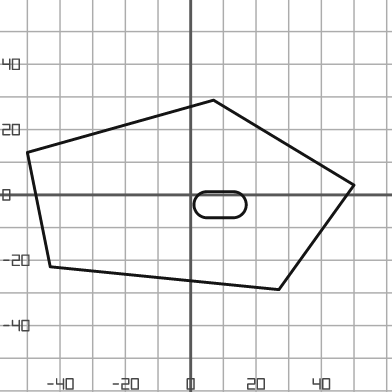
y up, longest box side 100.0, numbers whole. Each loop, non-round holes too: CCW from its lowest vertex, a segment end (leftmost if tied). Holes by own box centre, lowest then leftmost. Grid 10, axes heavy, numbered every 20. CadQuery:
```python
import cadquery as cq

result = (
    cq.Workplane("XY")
    .moveTo(27.0, -29.0)
    .lineTo(50.0, 3.0)
    .lineTo(7.0, 29.0)
    .lineTo(-50.0, 13.0)
    .lineTo(-43.0, -22.0)
    .close()
    .moveTo(5.0, -7.0)
    .lineTo(13.0, -7.0)
    .threePointArc((17.0, -3.0), (13.0, 1.0))
    .lineTo(5.0, 1.0)
    .threePointArc((1.0, -3.0), (5.0, -7.0))
    .close()
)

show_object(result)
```